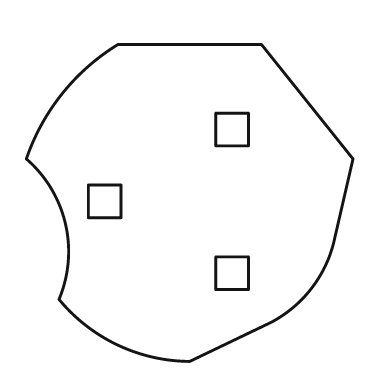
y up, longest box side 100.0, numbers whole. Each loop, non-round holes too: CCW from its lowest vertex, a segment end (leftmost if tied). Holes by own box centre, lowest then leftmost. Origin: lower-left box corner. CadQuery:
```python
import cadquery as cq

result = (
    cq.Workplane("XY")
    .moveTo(50.0, 0.0)
    .lineTo(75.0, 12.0)
    .threePointArc((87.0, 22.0), (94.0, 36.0))
    .lineTo(100.0, 62.0)
    .lineTo(72.0, 97.0)
    .lineTo(28.0, 97.0)
    .threePointArc((11.0, 82.0), (0.0, 62.0))
    .threePointArc((12.0, 42.0), (10.0, 19.0))
    .threePointArc((28.0, 5.0), (50.0, 0.0))
    .close()
    .moveTo(58.0, 22.0)
    .lineTo(68.0, 22.0)
    .lineTo(68.0, 32.0)
    .lineTo(58.0, 32.0)
    .close()
    .moveTo(19.0, 44.0)
    .lineTo(29.0, 44.0)
    .lineTo(29.0, 54.0)
    .lineTo(19.0, 54.0)
    .close()
    .moveTo(58.0, 66.0)
    .lineTo(68.0, 66.0)
    .lineTo(68.0, 76.0)
    .lineTo(58.0, 76.0)
    .close()
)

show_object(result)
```